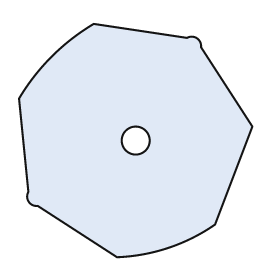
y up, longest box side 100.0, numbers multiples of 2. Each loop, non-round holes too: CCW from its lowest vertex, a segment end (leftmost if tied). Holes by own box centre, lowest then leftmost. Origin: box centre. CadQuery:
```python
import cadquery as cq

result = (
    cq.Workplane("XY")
    .moveTo(-8.0, -50.0)
    .threePointArc((14.0, -46.0), (34.0, -36.0))
    .lineTo(50.0, 6.0)
    .lineTo(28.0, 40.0)
    .threePointArc((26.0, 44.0), (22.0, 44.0))
    .lineTo(-18.0, 50.0)
    .threePointArc((-36.0, 36.0), (-50.0, 18.0))
    .lineTo(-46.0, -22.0)
    .threePointArc((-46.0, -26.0), (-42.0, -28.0))
    .close()
    .moveTo(0.0, 0.0)
    .circle(6.0)
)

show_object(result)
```